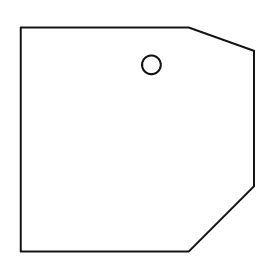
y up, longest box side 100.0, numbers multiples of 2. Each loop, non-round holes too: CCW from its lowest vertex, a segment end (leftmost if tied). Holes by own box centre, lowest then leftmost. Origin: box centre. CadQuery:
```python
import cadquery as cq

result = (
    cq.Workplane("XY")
    .moveTo(-50.0, -48.0)
    .lineTo(22.0, -48.0)
    .lineTo(50.0, -20.0)
    .lineTo(50.0, 38.0)
    .lineTo(22.0, 48.0)
    .lineTo(-50.0, 48.0)
    .close()
    .moveTo(6.0, 32.0)
    .circle(4.0)
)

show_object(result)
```